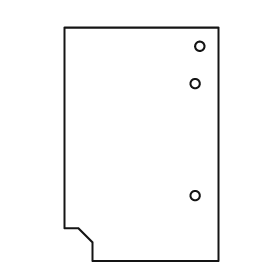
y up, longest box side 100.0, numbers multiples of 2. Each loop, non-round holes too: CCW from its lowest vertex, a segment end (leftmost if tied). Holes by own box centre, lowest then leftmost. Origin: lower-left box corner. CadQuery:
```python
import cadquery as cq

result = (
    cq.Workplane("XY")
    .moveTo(12.0, 0.0)
    .lineTo(66.0, 0.0)
    .lineTo(66.0, 100.0)
    .lineTo(0.0, 100.0)
    .lineTo(0.0, 14.0)
    .lineTo(6.0, 14.0)
    .lineTo(12.0, 8.0)
    .close()
    .moveTo(56.0, 28.0)
    .circle(2.0)
    .moveTo(56.0, 76.0)
    .circle(2.0)
    .moveTo(58.0, 92.0)
    .circle(2.0)
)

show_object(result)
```